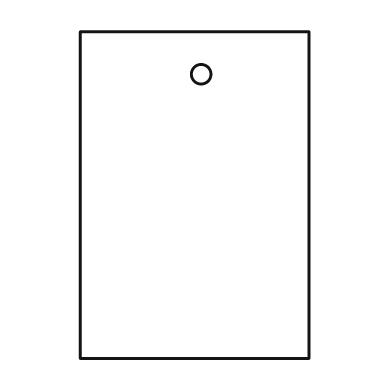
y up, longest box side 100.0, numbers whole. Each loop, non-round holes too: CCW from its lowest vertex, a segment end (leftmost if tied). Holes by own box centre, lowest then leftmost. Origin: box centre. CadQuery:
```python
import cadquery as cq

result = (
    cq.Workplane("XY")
    .moveTo(-35.0, -50.0)
    .lineTo(35.0, -50.0)
    .lineTo(35.0, 50.0)
    .lineTo(-35.0, 50.0)
    .close()
    .moveTo(2.0, 37.0)
    .circle(3.0)
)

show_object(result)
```